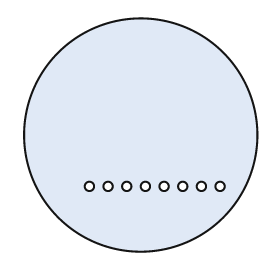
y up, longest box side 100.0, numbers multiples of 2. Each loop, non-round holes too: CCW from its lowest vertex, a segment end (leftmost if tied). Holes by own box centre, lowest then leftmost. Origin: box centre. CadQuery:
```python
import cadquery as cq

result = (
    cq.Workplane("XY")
    .moveTo(0.0, 0.0)
    .circle(50.0)
    .moveTo(-22.0, -22.0)
    .circle(2.0)
    .moveTo(-14.0, -22.0)
    .circle(2.0)
    .moveTo(-6.0, -22.0)
    .circle(2.0)
    .moveTo(2.0, -22.0)
    .circle(2.0)
    .moveTo(10.0, -22.0)
    .circle(2.0)
    .moveTo(18.0, -22.0)
    .circle(2.0)
    .moveTo(26.0, -22.0)
    .circle(2.0)
    .moveTo(34.0, -22.0)
    .circle(2.0)
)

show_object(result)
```